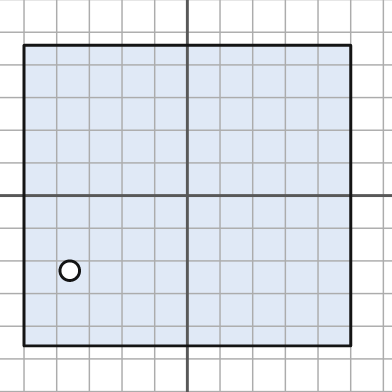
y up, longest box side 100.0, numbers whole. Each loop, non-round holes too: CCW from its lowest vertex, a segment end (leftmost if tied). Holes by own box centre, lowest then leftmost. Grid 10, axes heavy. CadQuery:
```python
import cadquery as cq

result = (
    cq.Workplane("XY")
    .moveTo(-50.0, -46.0)
    .lineTo(50.0, -46.0)
    .lineTo(50.0, 46.0)
    .lineTo(-50.0, 46.0)
    .close()
    .moveTo(-36.0, -23.0)
    .circle(3.0)
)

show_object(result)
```